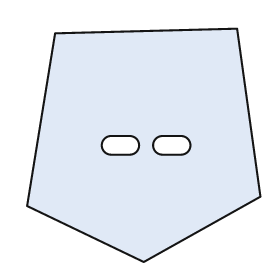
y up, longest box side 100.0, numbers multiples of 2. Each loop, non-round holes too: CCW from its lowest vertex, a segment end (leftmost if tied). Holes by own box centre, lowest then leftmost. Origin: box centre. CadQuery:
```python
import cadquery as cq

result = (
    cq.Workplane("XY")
    .moveTo(0.0, -50.0)
    .lineTo(50.0, -22.0)
    .lineTo(40.0, 50.0)
    .lineTo(-38.0, 48.0)
    .lineTo(-50.0, -26.0)
    .close()
    .moveTo(-14.0, -4.0)
    .lineTo(-6.0, -4.0)
    .threePointArc((-2.0, 0.0), (-6.0, 4.0))
    .lineTo(-14.0, 4.0)
    .threePointArc((-18.0, 0.0), (-14.0, -4.0))
    .close()
    .moveTo(8.0, -4.0)
    .lineTo(16.0, -4.0)
    .threePointArc((20.0, 0.0), (16.0, 4.0))
    .lineTo(8.0, 4.0)
    .threePointArc((4.0, 0.0), (8.0, -4.0))
    .close()
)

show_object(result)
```